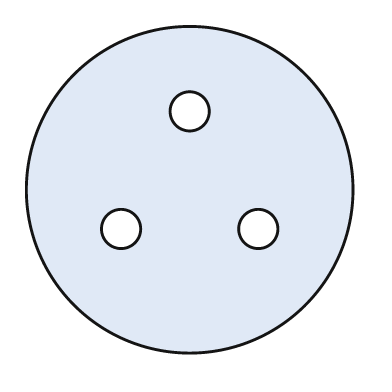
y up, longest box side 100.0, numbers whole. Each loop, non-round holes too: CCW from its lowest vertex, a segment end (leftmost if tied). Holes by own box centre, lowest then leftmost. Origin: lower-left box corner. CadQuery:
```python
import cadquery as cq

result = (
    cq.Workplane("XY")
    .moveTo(50.0, 50.0)
    .circle(50.0)
    .moveTo(29.0, 38.0)
    .circle(6.0)
    .moveTo(71.0, 38.0)
    .circle(6.0)
    .moveTo(50.0, 74.0)
    .circle(6.0)
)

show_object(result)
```